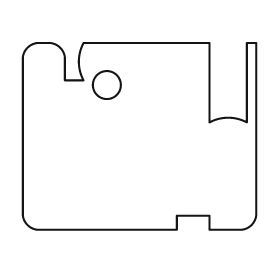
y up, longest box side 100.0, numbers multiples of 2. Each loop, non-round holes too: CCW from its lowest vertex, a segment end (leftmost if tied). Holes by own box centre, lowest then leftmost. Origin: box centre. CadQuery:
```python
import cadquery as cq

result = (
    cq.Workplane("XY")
    .moveTo(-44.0, -40.0)
    .lineTo(16.0, -40.0)
    .lineTo(16.0, -34.0)
    .lineTo(30.0, -34.0)
    .lineTo(30.0, -40.0)
    .lineTo(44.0, -40.0)
    .threePointArc((48.0, -38.0), (50.0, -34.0))
    .lineTo(50.0, 40.0)
    .lineTo(46.0, 40.0)
    .lineTo(46.0, 6.0)
    .threePointArc((38.0, 8.0), (30.0, 6.0))
    .lineTo(30.0, 40.0)
    .lineTo(-24.0, 40.0)
    .threePointArc((-26.0, 32.0), (-24.0, 24.0))
    .lineTo(-32.0, 24.0)
    .lineTo(-32.0, 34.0)
    .threePointArc((-34.0, 38.0), (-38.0, 40.0))
    .lineTo(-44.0, 40.0)
    .threePointArc((-48.0, 38.0), (-50.0, 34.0))
    .lineTo(-50.0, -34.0)
    .threePointArc((-48.0, -38.0), (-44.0, -40.0))
    .close()
    .moveTo(-14.0, 22.0)
    .circle(6.0)
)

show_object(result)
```